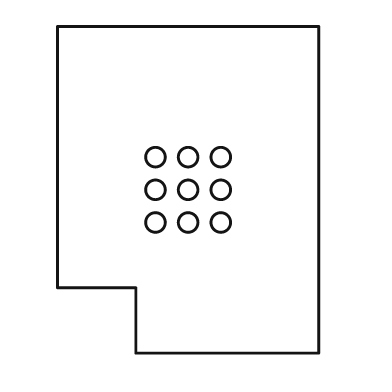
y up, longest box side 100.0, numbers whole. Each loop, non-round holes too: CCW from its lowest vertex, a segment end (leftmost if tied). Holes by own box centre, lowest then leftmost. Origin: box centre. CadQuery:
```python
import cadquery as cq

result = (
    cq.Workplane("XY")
    .moveTo(-16.0, -50.0)
    .lineTo(40.0, -50.0)
    .lineTo(40.0, 50.0)
    .lineTo(-40.0, 50.0)
    .lineTo(-40.0, -30.0)
    .lineTo(-16.0, -30.0)
    .close()
    .moveTo(-10.0, -10.0)
    .circle(3.0)
    .moveTo(0.0, -10.0)
    .circle(3.0)
    .moveTo(10.0, -10.0)
    .circle(3.0)
    .moveTo(-10.0, 0.0)
    .circle(3.0)
    .moveTo(0.0, 0.0)
    .circle(3.0)
    .moveTo(10.0, 0.0)
    .circle(3.0)
    .moveTo(-10.0, 10.0)
    .circle(3.0)
    .moveTo(0.0, 10.0)
    .circle(3.0)
    .moveTo(10.0, 10.0)
    .circle(3.0)
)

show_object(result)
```